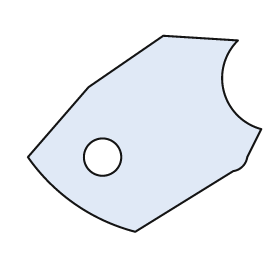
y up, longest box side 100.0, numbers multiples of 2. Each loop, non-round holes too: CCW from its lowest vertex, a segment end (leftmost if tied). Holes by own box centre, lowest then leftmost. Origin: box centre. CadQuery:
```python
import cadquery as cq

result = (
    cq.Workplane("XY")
    .moveTo(-4.0, -42.0)
    .lineTo(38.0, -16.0)
    .threePointArc((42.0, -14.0), (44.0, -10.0))
    .lineTo(50.0, 2.0)
    .threePointArc((34.0, 18.0), (40.0, 40.0))
    .lineTo(8.0, 42.0)
    .lineTo(-24.0, 20.0)
    .lineTo(-50.0, -10.0)
    .threePointArc((-30.0, -30.0), (-4.0, -42.0))
    .close()
    .moveTo(-18.0, -10.0)
    .circle(8.0)
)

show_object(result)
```